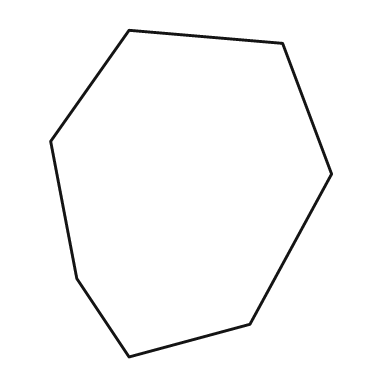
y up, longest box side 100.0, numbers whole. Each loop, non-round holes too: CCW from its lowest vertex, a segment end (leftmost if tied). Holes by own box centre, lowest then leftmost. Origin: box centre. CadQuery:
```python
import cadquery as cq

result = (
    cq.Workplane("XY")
    .moveTo(-19.0, -50.0)
    .lineTo(18.0, -40.0)
    .lineTo(43.0, 6.0)
    .lineTo(28.0, 46.0)
    .lineTo(-19.0, 50.0)
    .lineTo(-43.0, 16.0)
    .lineTo(-35.0, -26.0)
    .close()
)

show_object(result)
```